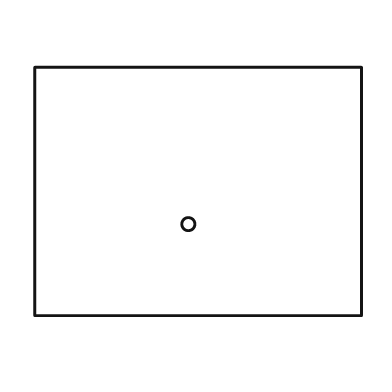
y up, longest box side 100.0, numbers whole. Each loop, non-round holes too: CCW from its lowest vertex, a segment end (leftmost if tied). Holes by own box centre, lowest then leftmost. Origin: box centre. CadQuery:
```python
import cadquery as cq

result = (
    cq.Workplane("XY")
    .moveTo(-50.0, -38.0)
    .lineTo(50.0, -38.0)
    .lineTo(50.0, 38.0)
    .lineTo(-50.0, 38.0)
    .close()
    .moveTo(-3.0, -10.0)
    .circle(2.0)
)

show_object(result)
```